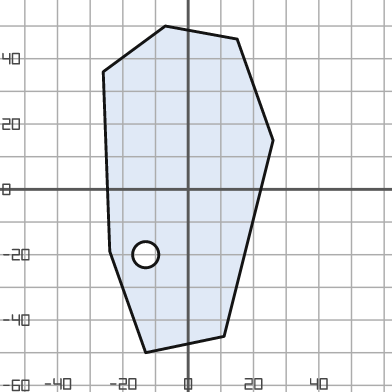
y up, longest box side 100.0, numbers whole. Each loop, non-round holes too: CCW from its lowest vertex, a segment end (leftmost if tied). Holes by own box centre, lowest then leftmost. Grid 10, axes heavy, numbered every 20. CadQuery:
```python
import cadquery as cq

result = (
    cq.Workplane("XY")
    .moveTo(-13.0, -50.0)
    .lineTo(11.0, -45.0)
    .lineTo(26.0, 15.0)
    .lineTo(15.0, 46.0)
    .lineTo(-7.0, 50.0)
    .lineTo(-26.0, 36.0)
    .lineTo(-24.0, -19.0)
    .close()
    .moveTo(-13.0, -20.0)
    .circle(4.0)
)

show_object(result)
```